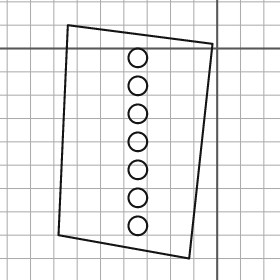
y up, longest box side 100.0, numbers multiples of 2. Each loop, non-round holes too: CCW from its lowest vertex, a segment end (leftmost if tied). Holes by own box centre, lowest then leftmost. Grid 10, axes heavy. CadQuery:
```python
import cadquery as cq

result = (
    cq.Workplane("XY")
    .moveTo(-12.0, -90.0)
    .lineTo(-2.0, 2.0)
    .lineTo(-64.0, 10.0)
    .lineTo(-68.0, -80.0)
    .close()
    .moveTo(-34.0, -76.0)
    .circle(4.0)
    .moveTo(-34.0, -64.0)
    .circle(4.0)
    .moveTo(-34.0, -52.0)
    .circle(4.0)
    .moveTo(-34.0, -40.0)
    .circle(4.0)
    .moveTo(-34.0, -28.0)
    .circle(4.0)
    .moveTo(-34.0, -16.0)
    .circle(4.0)
    .moveTo(-34.0, -4.0)
    .circle(4.0)
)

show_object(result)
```